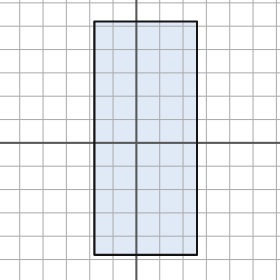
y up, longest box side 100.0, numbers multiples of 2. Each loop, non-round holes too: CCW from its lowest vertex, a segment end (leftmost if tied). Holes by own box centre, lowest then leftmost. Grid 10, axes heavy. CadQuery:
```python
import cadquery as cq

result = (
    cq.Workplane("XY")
    .moveTo(-18.0, -48.0)
    .lineTo(26.0, -48.0)
    .lineTo(26.0, 52.0)
    .lineTo(-18.0, 52.0)
    .close()
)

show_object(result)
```